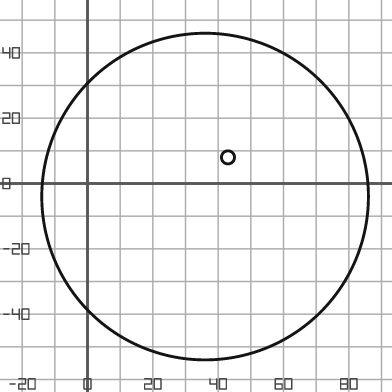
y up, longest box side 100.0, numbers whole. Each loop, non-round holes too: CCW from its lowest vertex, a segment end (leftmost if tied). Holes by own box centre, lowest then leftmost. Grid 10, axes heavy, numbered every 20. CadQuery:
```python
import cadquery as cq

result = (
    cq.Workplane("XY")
    .moveTo(36.0, -4.0)
    .circle(50.0)
    .moveTo(43.0, 8.0)
    .circle(2.0)
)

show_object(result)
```